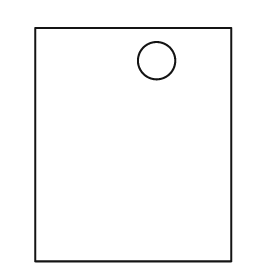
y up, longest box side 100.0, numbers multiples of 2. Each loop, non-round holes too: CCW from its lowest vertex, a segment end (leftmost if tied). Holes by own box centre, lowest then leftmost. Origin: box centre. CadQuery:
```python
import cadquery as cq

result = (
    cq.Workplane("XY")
    .moveTo(-42.0, -50.0)
    .lineTo(42.0, -50.0)
    .lineTo(42.0, 50.0)
    .lineTo(-42.0, 50.0)
    .close()
    .moveTo(10.0, 36.0)
    .circle(8.0)
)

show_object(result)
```